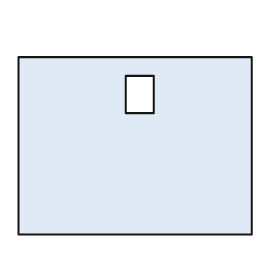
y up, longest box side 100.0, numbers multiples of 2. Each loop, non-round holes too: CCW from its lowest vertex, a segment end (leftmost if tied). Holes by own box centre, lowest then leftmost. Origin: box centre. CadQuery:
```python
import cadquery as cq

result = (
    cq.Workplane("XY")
    .moveTo(-50.0, -38.0)
    .lineTo(50.0, -38.0)
    .lineTo(50.0, 38.0)
    .lineTo(-50.0, 38.0)
    .close()
    .moveTo(-4.0, 14.0)
    .lineTo(8.0, 14.0)
    .lineTo(8.0, 30.0)
    .lineTo(-4.0, 30.0)
    .close()
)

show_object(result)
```